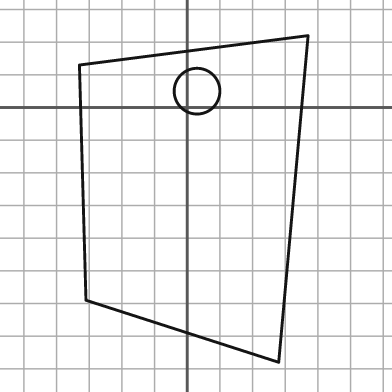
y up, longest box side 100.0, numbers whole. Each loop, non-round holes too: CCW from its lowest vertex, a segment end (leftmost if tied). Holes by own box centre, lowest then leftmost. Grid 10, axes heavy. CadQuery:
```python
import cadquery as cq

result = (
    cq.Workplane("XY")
    .moveTo(28.0, -78.0)
    .lineTo(37.0, 22.0)
    .lineTo(-33.0, 13.0)
    .lineTo(-31.0, -59.0)
    .close()
    .moveTo(3.0, 5.0)
    .circle(7.0)
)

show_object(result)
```